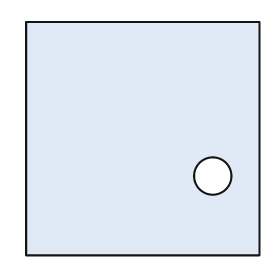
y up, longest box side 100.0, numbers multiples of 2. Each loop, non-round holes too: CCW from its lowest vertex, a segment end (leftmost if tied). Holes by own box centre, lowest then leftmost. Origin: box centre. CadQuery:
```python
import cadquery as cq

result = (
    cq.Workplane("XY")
    .moveTo(-50.0, -50.0)
    .lineTo(50.0, -50.0)
    .lineTo(50.0, 50.0)
    .lineTo(-50.0, 50.0)
    .close()
    .moveTo(30.0, -16.0)
    .circle(8.0)
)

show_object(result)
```